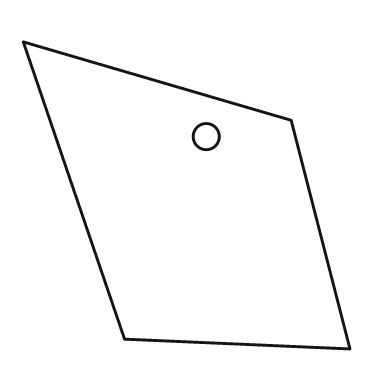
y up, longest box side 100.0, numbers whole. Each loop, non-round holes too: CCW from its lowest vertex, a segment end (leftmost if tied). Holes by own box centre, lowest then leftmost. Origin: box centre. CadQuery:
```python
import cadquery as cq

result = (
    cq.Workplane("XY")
    .moveTo(50.0, -47.0)
    .lineTo(32.0, 23.0)
    .lineTo(-50.0, 47.0)
    .lineTo(-19.0, -44.0)
    .close()
    .moveTo(6.0, 18.0)
    .circle(4.0)
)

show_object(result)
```